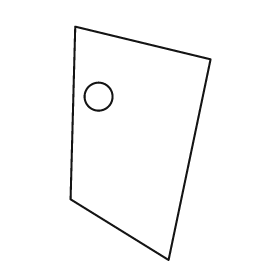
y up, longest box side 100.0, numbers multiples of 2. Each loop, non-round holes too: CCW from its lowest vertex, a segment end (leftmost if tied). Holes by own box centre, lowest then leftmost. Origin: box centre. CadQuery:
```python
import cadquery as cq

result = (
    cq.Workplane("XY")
    .moveTo(12.0, -50.0)
    .lineTo(30.0, 36.0)
    .lineTo(-28.0, 50.0)
    .lineTo(-30.0, -24.0)
    .close()
    .moveTo(-18.0, 20.0)
    .circle(6.0)
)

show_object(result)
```